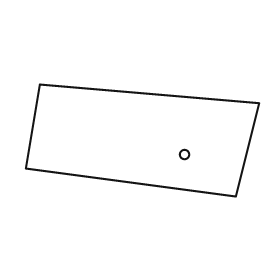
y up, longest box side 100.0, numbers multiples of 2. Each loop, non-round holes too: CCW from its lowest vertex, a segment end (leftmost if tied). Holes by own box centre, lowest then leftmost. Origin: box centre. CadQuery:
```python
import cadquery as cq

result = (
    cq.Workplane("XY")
    .moveTo(40.0, -24.0)
    .lineTo(50.0, 16.0)
    .lineTo(-44.0, 24.0)
    .lineTo(-50.0, -12.0)
    .close()
    .moveTo(18.0, -6.0)
    .circle(2.0)
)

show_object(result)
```